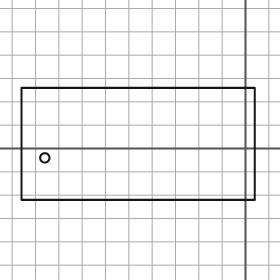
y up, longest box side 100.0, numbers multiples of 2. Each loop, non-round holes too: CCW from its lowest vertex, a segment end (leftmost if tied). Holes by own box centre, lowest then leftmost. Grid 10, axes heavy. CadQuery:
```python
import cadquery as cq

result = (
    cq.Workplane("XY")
    .moveTo(-96.0, -22.0)
    .lineTo(4.0, -22.0)
    .lineTo(4.0, 26.0)
    .lineTo(-96.0, 26.0)
    .close()
    .moveTo(-86.0, -4.0)
    .circle(2.0)
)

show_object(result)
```